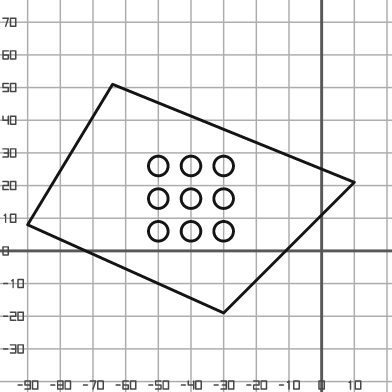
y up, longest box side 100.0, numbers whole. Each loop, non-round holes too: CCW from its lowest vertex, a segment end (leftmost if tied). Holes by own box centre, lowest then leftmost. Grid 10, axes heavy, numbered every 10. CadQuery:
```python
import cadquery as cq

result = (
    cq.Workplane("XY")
    .moveTo(-30.0, -19.0)
    .lineTo(10.0, 21.0)
    .lineTo(-64.0, 51.0)
    .lineTo(-90.0, 8.0)
    .close()
    .moveTo(-50.0, 6.0)
    .circle(3.0)
    .moveTo(-40.0, 6.0)
    .circle(3.0)
    .moveTo(-30.0, 6.0)
    .circle(3.0)
    .moveTo(-50.0, 16.0)
    .circle(3.0)
    .moveTo(-40.0, 16.0)
    .circle(3.0)
    .moveTo(-30.0, 16.0)
    .circle(3.0)
    .moveTo(-50.0, 26.0)
    .circle(3.0)
    .moveTo(-40.0, 26.0)
    .circle(3.0)
    .moveTo(-30.0, 26.0)
    .circle(3.0)
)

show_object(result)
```